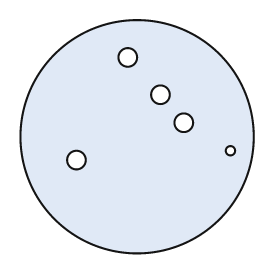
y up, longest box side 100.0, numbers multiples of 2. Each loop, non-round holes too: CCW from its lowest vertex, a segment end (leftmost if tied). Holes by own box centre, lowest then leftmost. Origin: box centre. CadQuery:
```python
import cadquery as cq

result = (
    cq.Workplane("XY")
    .moveTo(0.0, 0.0)
    .circle(50.0)
    .moveTo(-26.0, -10.0)
    .circle(4.0)
    .moveTo(40.0, -6.0)
    .circle(2.0)
    .moveTo(20.0, 6.0)
    .circle(4.0)
    .moveTo(10.0, 18.0)
    .circle(4.0)
    .moveTo(-4.0, 34.0)
    .circle(4.0)
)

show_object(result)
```